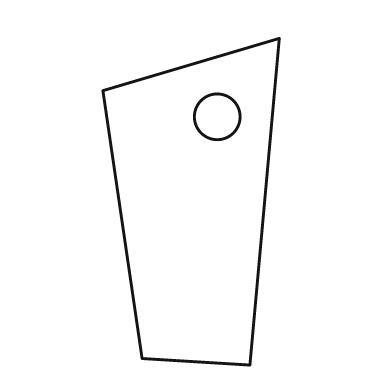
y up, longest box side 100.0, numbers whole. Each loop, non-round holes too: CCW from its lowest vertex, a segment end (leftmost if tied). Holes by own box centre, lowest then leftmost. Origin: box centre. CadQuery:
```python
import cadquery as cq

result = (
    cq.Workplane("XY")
    .moveTo(18.0, -50.0)
    .lineTo(27.0, 50.0)
    .lineTo(-27.0, 34.0)
    .lineTo(-15.0, -48.0)
    .close()
    .moveTo(8.0, 26.0)
    .circle(7.0)
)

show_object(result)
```